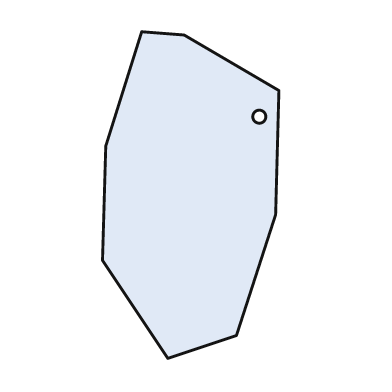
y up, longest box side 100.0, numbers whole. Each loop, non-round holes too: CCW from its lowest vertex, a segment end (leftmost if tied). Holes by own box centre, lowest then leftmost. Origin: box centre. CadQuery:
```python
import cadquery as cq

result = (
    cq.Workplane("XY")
    .moveTo(-7.0, -50.0)
    .lineTo(14.0, -43.0)
    .lineTo(26.0, -6.0)
    .lineTo(27.0, 32.0)
    .lineTo(-2.0, 49.0)
    .lineTo(-15.0, 50.0)
    .lineTo(-26.0, 15.0)
    .lineTo(-27.0, -20.0)
    .close()
    .moveTo(21.0, 24.0)
    .circle(2.0)
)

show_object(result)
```